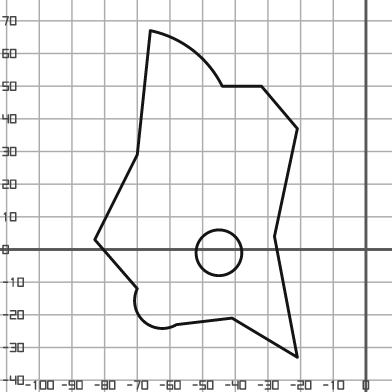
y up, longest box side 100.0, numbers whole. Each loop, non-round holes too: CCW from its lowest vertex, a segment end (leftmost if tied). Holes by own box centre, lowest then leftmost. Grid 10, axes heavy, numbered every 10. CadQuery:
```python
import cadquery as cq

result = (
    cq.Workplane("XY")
    .moveTo(-21.0, -33.0)
    .lineTo(-28.0, 4.0)
    .lineTo(-21.0, 37.0)
    .lineTo(-32.0, 50.0)
    .lineTo(-44.0, 50.0)
    .threePointArc((-53.0, 61.0), (-66.0, 67.0))
    .lineTo(-70.0, 29.0)
    .lineTo(-83.0, 3.0)
    .lineTo(-70.0, -12.0)
    .threePointArc((-68.0, -22.0), (-58.0, -23.0))
    .lineTo(-41.0, -21.0)
    .close()
    .moveTo(-45.0, -1.0)
    .circle(7.0)
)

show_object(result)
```